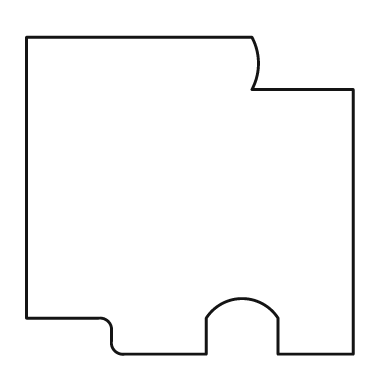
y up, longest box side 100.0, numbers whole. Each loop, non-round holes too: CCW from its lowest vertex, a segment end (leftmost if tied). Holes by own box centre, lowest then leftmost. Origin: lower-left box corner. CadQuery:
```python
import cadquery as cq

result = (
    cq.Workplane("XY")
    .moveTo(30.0, 0.0)
    .lineTo(55.0, 0.0)
    .lineTo(55.0, 11.0)
    .threePointArc((66.0, 17.0), (77.0, 11.0))
    .lineTo(77.0, 0.0)
    .lineTo(100.0, 0.0)
    .lineTo(100.0, 81.0)
    .lineTo(69.0, 81.0)
    .threePointArc((71.0, 89.0), (69.0, 97.0))
    .lineTo(0.0, 97.0)
    .lineTo(0.0, 11.0)
    .lineTo(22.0, 11.0)
    .threePointArc((25.0, 10.0), (26.0, 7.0))
    .lineTo(26.0, 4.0)
    .threePointArc((27.0, 1.0), (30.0, 0.0))
    .close()
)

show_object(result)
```